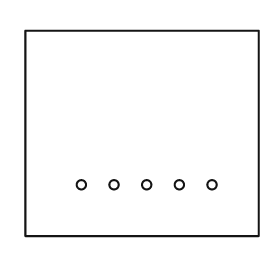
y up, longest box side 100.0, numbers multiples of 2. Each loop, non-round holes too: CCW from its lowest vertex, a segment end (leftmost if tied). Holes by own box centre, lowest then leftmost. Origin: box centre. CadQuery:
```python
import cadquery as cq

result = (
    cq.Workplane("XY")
    .moveTo(-50.0, -44.0)
    .lineTo(50.0, -44.0)
    .lineTo(50.0, 44.0)
    .lineTo(-50.0, 44.0)
    .close()
    .moveTo(-26.0, -22.0)
    .circle(2.0)
    .moveTo(-12.0, -22.0)
    .circle(2.0)
    .moveTo(2.0, -22.0)
    .circle(2.0)
    .moveTo(16.0, -22.0)
    .circle(2.0)
    .moveTo(30.0, -22.0)
    .circle(2.0)
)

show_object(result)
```